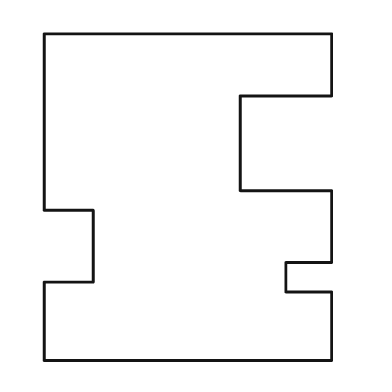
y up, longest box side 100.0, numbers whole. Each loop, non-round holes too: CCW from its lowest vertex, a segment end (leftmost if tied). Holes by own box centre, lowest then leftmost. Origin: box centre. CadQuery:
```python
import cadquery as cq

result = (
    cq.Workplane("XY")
    .moveTo(-44.0, -50.0)
    .lineTo(44.0, -50.0)
    .lineTo(44.0, -29.0)
    .lineTo(30.0, -29.0)
    .lineTo(30.0, -20.0)
    .lineTo(44.0, -20.0)
    .lineTo(44.0, 2.0)
    .lineTo(16.0, 2.0)
    .lineTo(16.0, 31.0)
    .lineTo(44.0, 31.0)
    .lineTo(44.0, 50.0)
    .lineTo(-44.0, 50.0)
    .lineTo(-44.0, -4.0)
    .lineTo(-29.0, -4.0)
    .lineTo(-29.0, -26.0)
    .lineTo(-44.0, -26.0)
    .close()
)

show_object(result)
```